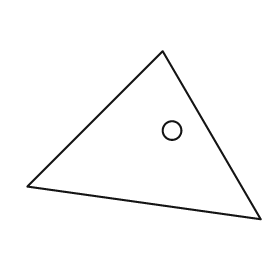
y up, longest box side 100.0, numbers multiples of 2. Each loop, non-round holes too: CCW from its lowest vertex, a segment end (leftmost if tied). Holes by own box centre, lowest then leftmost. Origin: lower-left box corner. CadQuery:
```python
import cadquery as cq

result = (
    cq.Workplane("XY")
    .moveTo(100.0, 0.0)
    .lineTo(58.0, 72.0)
    .lineTo(0.0, 14.0)
    .close()
    .moveTo(62.0, 38.0)
    .circle(4.0)
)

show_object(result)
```